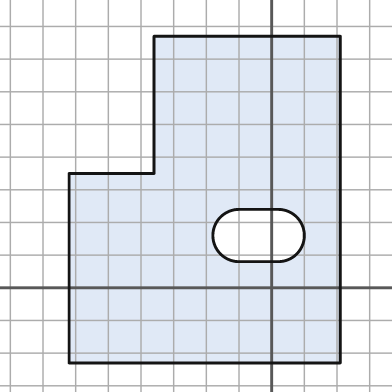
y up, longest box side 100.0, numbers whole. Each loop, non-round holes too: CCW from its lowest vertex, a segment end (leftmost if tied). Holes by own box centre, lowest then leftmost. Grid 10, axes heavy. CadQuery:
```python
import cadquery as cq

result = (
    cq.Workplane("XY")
    .moveTo(-62.0, -23.0)
    .lineTo(21.0, -23.0)
    .lineTo(21.0, 77.0)
    .lineTo(-36.0, 77.0)
    .lineTo(-36.0, 35.0)
    .lineTo(-62.0, 35.0)
    .close()
    .moveTo(-10.0, 8.0)
    .lineTo(2.0, 8.0)
    .threePointArc((10.0, 16.0), (2.0, 24.0))
    .lineTo(-10.0, 24.0)
    .threePointArc((-18.0, 16.0), (-10.0, 8.0))
    .close()
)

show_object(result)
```